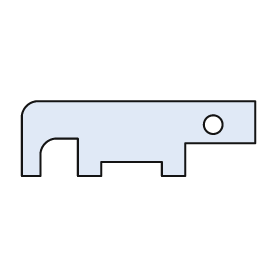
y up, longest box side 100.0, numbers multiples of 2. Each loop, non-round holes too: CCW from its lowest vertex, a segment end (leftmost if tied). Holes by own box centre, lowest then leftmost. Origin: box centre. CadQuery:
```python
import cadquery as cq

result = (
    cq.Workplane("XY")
    .moveTo(-50.0, -16.0)
    .lineTo(-42.0, -16.0)
    .lineTo(-42.0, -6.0)
    .threePointArc((-40.0, -2.0), (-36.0, 0.0))
    .lineTo(-26.0, 0.0)
    .lineTo(-26.0, -16.0)
    .lineTo(-16.0, -16.0)
    .lineTo(-16.0, -10.0)
    .lineTo(10.0, -10.0)
    .lineTo(10.0, -16.0)
    .lineTo(20.0, -16.0)
    .lineTo(20.0, -2.0)
    .lineTo(50.0, -2.0)
    .lineTo(50.0, 16.0)
    .lineTo(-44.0, 16.0)
    .threePointArc((-48.0, 14.0), (-50.0, 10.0))
    .close()
    .moveTo(32.0, 6.0)
    .circle(4.0)
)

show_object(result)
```